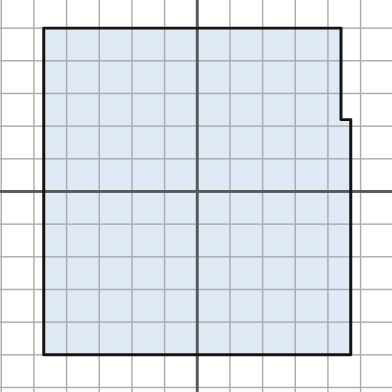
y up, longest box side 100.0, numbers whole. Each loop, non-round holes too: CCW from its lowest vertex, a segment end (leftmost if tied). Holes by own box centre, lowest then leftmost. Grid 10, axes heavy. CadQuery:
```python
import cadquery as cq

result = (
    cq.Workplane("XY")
    .moveTo(-47.0, -50.0)
    .lineTo(47.0, -50.0)
    .lineTo(47.0, 22.0)
    .lineTo(44.0, 22.0)
    .lineTo(44.0, 50.0)
    .lineTo(-47.0, 50.0)
    .close()
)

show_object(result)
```